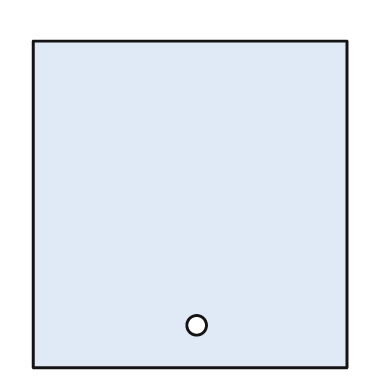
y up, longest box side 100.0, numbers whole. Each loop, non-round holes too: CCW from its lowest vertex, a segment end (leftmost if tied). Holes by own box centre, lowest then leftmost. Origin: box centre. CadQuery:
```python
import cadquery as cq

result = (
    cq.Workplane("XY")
    .moveTo(-48.0, -50.0)
    .lineTo(48.0, -50.0)
    .lineTo(48.0, 50.0)
    .lineTo(-48.0, 50.0)
    .close()
    .moveTo(2.0, -37.0)
    .circle(3.0)
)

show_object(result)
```